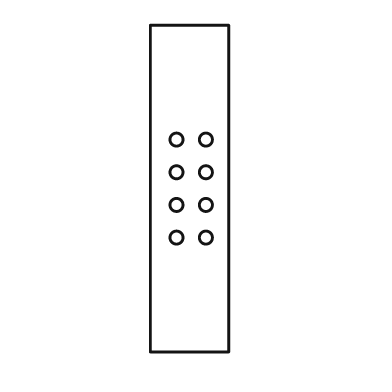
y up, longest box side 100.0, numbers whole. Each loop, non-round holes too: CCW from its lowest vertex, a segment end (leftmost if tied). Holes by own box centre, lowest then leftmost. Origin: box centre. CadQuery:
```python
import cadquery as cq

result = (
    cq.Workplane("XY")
    .moveTo(-12.0, -50.0)
    .lineTo(12.0, -50.0)
    .lineTo(12.0, 50.0)
    .lineTo(-12.0, 50.0)
    .close()
    .moveTo(-4.0, -15.0)
    .circle(2.0)
    .moveTo(5.0, -15.0)
    .circle(2.0)
    .moveTo(-4.0, -5.0)
    .circle(2.0)
    .moveTo(5.0, -5.0)
    .circle(2.0)
    .moveTo(-4.0, 5.0)
    .circle(2.0)
    .moveTo(5.0, 5.0)
    .circle(2.0)
    .moveTo(-4.0, 15.0)
    .circle(2.0)
    .moveTo(5.0, 15.0)
    .circle(2.0)
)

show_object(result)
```